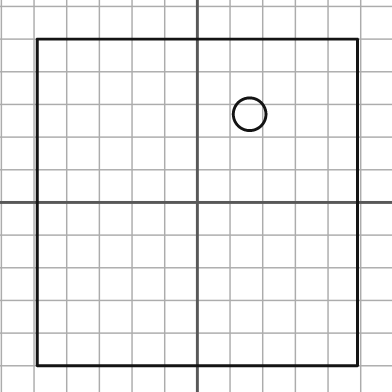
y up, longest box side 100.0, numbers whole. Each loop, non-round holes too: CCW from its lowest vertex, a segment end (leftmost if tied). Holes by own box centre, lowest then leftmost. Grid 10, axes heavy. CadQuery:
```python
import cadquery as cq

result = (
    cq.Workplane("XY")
    .moveTo(-49.0, -50.0)
    .lineTo(49.0, -50.0)
    .lineTo(49.0, 50.0)
    .lineTo(-49.0, 50.0)
    .close()
    .moveTo(16.0, 27.0)
    .circle(5.0)
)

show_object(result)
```